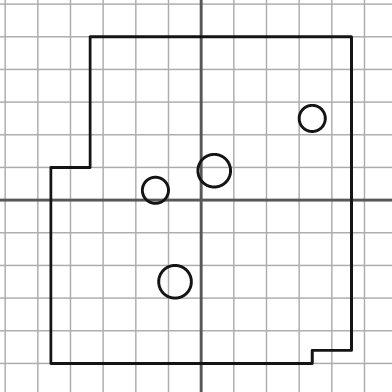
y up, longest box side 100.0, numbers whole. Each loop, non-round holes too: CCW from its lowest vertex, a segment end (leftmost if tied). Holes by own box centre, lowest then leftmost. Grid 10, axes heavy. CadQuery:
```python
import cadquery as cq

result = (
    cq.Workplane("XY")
    .moveTo(-46.0, -50.0)
    .lineTo(34.0, -50.0)
    .lineTo(34.0, -46.0)
    .lineTo(46.0, -46.0)
    .lineTo(46.0, 50.0)
    .lineTo(-34.0, 50.0)
    .lineTo(-34.0, 10.0)
    .lineTo(-46.0, 10.0)
    .close()
    .moveTo(-8.0, -25.0)
    .circle(5.0)
    .moveTo(-14.0, 3.0)
    .circle(4.0)
    .moveTo(4.0, 9.0)
    .circle(5.0)
    .moveTo(34.0, 25.0)
    .circle(4.0)
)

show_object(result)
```